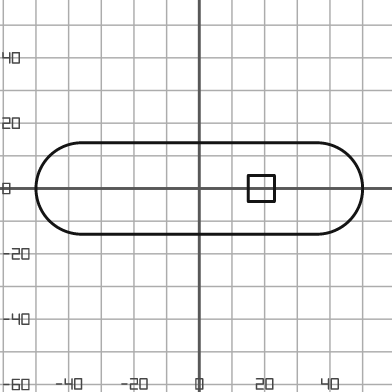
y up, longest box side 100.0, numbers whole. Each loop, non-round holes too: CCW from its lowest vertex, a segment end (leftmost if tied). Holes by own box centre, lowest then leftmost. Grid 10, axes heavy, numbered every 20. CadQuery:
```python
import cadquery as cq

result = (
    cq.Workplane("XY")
    .moveTo(-36.0, -14.0)
    .lineTo(36.0, -14.0)
    .threePointArc((50.0, 0.0), (36.0, 14.0))
    .lineTo(-36.0, 14.0)
    .threePointArc((-50.0, 0.0), (-36.0, -14.0))
    .close()
    .moveTo(15.0, -4.0)
    .lineTo(23.0, -4.0)
    .lineTo(23.0, 4.0)
    .lineTo(15.0, 4.0)
    .close()
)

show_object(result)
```